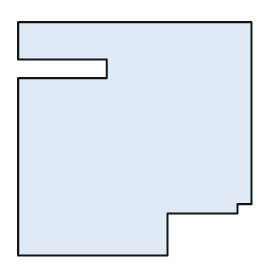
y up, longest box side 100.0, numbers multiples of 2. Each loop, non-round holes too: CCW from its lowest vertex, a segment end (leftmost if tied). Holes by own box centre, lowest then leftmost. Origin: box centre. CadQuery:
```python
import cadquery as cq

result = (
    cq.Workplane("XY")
    .moveTo(-50.0, -50.0)
    .lineTo(14.0, -50.0)
    .lineTo(14.0, -32.0)
    .lineTo(44.0, -32.0)
    .lineTo(44.0, -28.0)
    .lineTo(50.0, -28.0)
    .lineTo(50.0, 50.0)
    .lineTo(-50.0, 50.0)
    .lineTo(-50.0, 34.0)
    .lineTo(-12.0, 34.0)
    .lineTo(-12.0, 26.0)
    .lineTo(-50.0, 26.0)
    .close()
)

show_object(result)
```